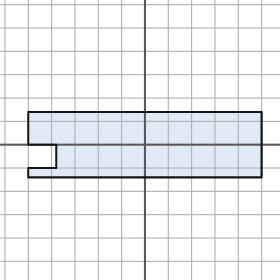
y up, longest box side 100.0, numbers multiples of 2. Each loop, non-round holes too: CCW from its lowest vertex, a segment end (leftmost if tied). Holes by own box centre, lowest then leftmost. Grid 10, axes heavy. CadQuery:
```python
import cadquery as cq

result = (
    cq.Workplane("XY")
    .moveTo(-50.0, -14.0)
    .lineTo(50.0, -14.0)
    .lineTo(50.0, 14.0)
    .lineTo(-50.0, 14.0)
    .lineTo(-50.0, 0.0)
    .lineTo(-38.0, 0.0)
    .lineTo(-38.0, -10.0)
    .lineTo(-50.0, -10.0)
    .close()
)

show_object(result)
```